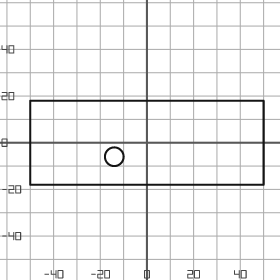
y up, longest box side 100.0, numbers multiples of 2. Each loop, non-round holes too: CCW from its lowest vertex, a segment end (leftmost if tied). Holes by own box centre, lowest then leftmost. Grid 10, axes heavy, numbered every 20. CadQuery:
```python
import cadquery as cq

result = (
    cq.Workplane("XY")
    .moveTo(-50.0, -18.0)
    .lineTo(50.0, -18.0)
    .lineTo(50.0, 18.0)
    .lineTo(-50.0, 18.0)
    .close()
    .moveTo(-14.0, -6.0)
    .circle(4.0)
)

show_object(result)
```